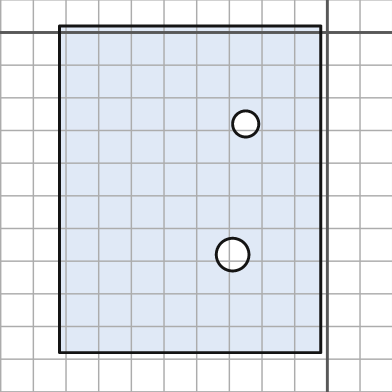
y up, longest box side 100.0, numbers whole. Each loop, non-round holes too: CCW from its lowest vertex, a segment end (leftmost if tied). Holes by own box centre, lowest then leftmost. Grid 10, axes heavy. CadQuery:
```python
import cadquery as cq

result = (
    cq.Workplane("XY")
    .moveTo(-82.0, -98.0)
    .lineTo(-2.0, -98.0)
    .lineTo(-2.0, 2.0)
    .lineTo(-82.0, 2.0)
    .close()
    .moveTo(-29.0, -68.0)
    .circle(5.0)
    .moveTo(-25.0, -28.0)
    .circle(4.0)
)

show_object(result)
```